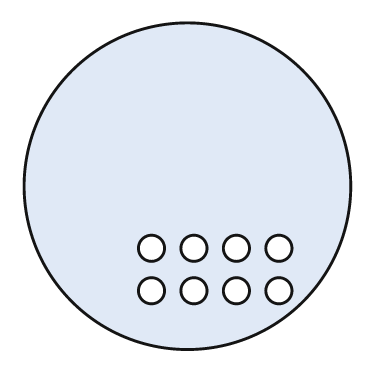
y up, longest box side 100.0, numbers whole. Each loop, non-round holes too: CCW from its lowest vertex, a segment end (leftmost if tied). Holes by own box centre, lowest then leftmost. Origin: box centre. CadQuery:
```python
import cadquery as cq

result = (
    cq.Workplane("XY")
    .moveTo(0.0, 0.0)
    .circle(50.0)
    .moveTo(-11.0, -32.0)
    .circle(4.0)
    .moveTo(2.0, -32.0)
    .circle(4.0)
    .moveTo(15.0, -32.0)
    .circle(4.0)
    .moveTo(28.0, -32.0)
    .circle(4.0)
    .moveTo(-11.0, -19.0)
    .circle(4.0)
    .moveTo(2.0, -19.0)
    .circle(4.0)
    .moveTo(15.0, -19.0)
    .circle(4.0)
    .moveTo(28.0, -19.0)
    .circle(4.0)
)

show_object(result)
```